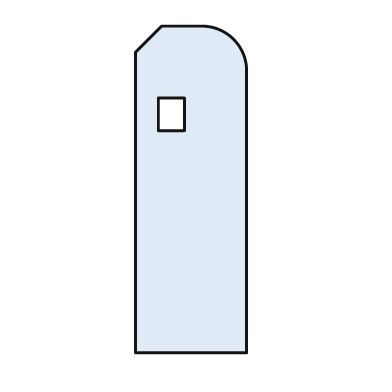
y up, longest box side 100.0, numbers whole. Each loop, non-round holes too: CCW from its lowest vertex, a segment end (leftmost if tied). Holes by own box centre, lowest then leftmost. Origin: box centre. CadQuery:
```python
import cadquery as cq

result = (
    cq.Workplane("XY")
    .moveTo(-17.0, -50.0)
    .lineTo(17.0, -50.0)
    .lineTo(17.0, 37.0)
    .threePointArc((13.0, 46.0), (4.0, 50.0))
    .lineTo(-9.0, 50.0)
    .lineTo(-17.0, 42.0)
    .close()
    .moveTo(-10.0, 18.0)
    .lineTo(-2.0, 18.0)
    .lineTo(-2.0, 28.0)
    .lineTo(-10.0, 28.0)
    .close()
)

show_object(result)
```